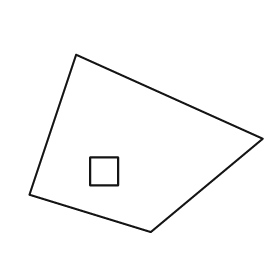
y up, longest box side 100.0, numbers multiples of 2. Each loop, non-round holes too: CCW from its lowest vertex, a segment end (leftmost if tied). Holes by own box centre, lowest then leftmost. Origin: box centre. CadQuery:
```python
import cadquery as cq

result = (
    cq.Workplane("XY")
    .moveTo(2.0, -38.0)
    .lineTo(50.0, 2.0)
    .lineTo(-30.0, 38.0)
    .lineTo(-50.0, -22.0)
    .close()
    .moveTo(-24.0, -18.0)
    .lineTo(-12.0, -18.0)
    .lineTo(-12.0, -6.0)
    .lineTo(-24.0, -6.0)
    .close()
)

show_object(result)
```